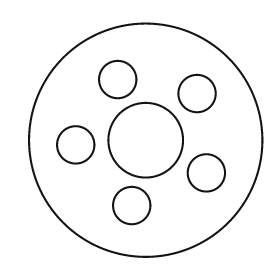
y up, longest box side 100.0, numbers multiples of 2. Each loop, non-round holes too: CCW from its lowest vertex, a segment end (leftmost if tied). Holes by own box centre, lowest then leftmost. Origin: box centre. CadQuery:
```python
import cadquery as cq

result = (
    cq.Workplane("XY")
    .moveTo(0.0, 0.0)
    .circle(50.0)
    .moveTo(-6.0, -28.0)
    .circle(8.0)
    .moveTo(26.0, -14.0)
    .circle(8.0)
    .moveTo(-30.0, -2.0)
    .circle(8.0)
    .moveTo(0.0, 0.0)
    .circle(16.0)
    .moveTo(22.0, 20.0)
    .circle(8.0)
    .moveTo(-12.0, 26.0)
    .circle(8.0)
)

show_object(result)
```